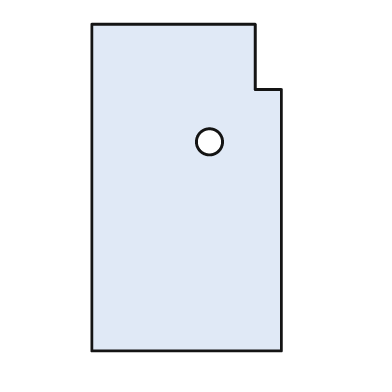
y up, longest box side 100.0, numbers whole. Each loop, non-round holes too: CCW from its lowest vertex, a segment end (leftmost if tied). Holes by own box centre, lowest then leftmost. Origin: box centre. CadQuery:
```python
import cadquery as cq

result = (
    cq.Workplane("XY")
    .moveTo(-29.0, -50.0)
    .lineTo(29.0, -50.0)
    .lineTo(29.0, 30.0)
    .lineTo(21.0, 30.0)
    .lineTo(21.0, 50.0)
    .lineTo(-29.0, 50.0)
    .close()
    .moveTo(7.0, 14.0)
    .circle(4.0)
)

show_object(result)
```